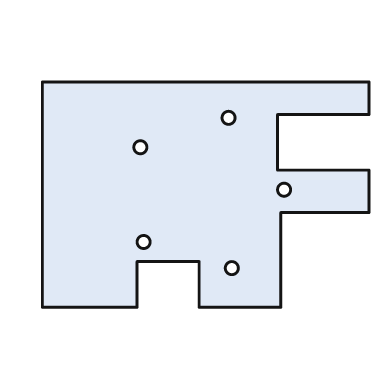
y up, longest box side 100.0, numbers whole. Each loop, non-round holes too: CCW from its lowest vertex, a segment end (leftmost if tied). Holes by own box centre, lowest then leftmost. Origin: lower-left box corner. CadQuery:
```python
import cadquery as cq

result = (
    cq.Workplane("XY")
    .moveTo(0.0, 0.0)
    .lineTo(29.0, 0.0)
    .lineTo(29.0, 14.0)
    .lineTo(48.0, 14.0)
    .lineTo(48.0, 0.0)
    .lineTo(73.0, 0.0)
    .lineTo(73.0, 29.0)
    .lineTo(100.0, 29.0)
    .lineTo(100.0, 42.0)
    .lineTo(72.0, 42.0)
    .lineTo(72.0, 59.0)
    .lineTo(100.0, 59.0)
    .lineTo(100.0, 69.0)
    .lineTo(0.0, 69.0)
    .close()
    .moveTo(58.0, 12.0)
    .circle(2.0)
    .moveTo(31.0, 20.0)
    .circle(2.0)
    .moveTo(74.0, 36.0)
    .circle(2.0)
    .moveTo(30.0, 49.0)
    .circle(2.0)
    .moveTo(57.0, 58.0)
    .circle(2.0)
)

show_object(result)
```